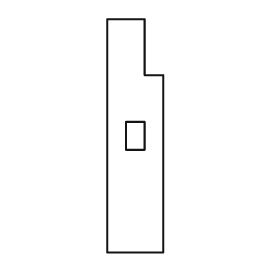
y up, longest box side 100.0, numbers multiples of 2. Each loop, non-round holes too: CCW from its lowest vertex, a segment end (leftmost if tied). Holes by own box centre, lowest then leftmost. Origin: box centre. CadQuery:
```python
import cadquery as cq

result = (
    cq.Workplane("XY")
    .moveTo(-12.0, -50.0)
    .lineTo(12.0, -50.0)
    .lineTo(12.0, 26.0)
    .lineTo(4.0, 26.0)
    .lineTo(4.0, 50.0)
    .lineTo(-12.0, 50.0)
    .close()
    .moveTo(-4.0, -6.0)
    .lineTo(4.0, -6.0)
    .lineTo(4.0, 6.0)
    .lineTo(-4.0, 6.0)
    .close()
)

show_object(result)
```